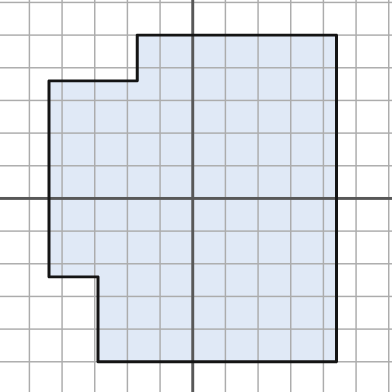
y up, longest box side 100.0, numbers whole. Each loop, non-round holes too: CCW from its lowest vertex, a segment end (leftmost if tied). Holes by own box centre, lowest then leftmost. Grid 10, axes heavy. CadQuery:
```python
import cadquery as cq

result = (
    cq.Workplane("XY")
    .moveTo(-29.0, -50.0)
    .lineTo(44.0, -50.0)
    .lineTo(44.0, 50.0)
    .lineTo(-17.0, 50.0)
    .lineTo(-17.0, 36.0)
    .lineTo(-44.0, 36.0)
    .lineTo(-44.0, -24.0)
    .lineTo(-29.0, -24.0)
    .close()
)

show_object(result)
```